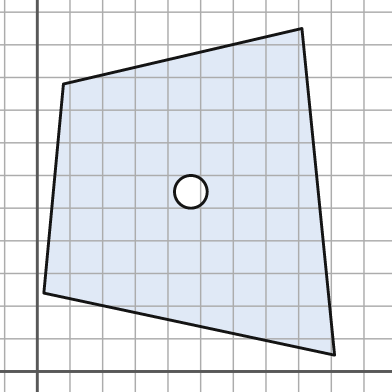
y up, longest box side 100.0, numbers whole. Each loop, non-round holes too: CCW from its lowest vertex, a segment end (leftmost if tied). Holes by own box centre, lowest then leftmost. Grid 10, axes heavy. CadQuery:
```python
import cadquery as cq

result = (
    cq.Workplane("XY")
    .moveTo(91.0, 5.0)
    .lineTo(81.0, 105.0)
    .lineTo(8.0, 88.0)
    .lineTo(2.0, 24.0)
    .close()
    .moveTo(47.0, 55.0)
    .circle(5.0)
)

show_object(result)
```